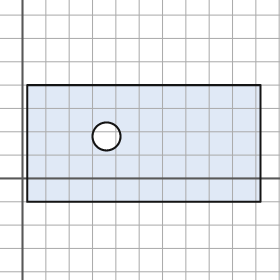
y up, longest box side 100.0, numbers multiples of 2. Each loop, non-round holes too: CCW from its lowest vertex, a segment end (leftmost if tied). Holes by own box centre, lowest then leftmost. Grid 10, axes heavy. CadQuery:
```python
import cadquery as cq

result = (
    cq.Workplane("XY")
    .moveTo(2.0, -10.0)
    .lineTo(102.0, -10.0)
    .lineTo(102.0, 40.0)
    .lineTo(2.0, 40.0)
    .close()
    .moveTo(36.0, 18.0)
    .circle(6.0)
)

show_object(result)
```